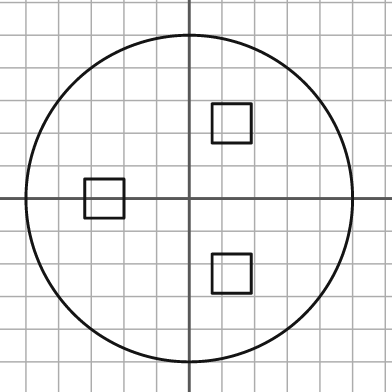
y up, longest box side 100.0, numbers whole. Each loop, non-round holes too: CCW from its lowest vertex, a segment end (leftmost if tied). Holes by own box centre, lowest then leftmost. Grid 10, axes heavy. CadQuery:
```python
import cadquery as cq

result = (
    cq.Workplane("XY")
    .moveTo(0.0, 0.0)
    .circle(50.0)
    .moveTo(7.0, -29.0)
    .lineTo(19.0, -29.0)
    .lineTo(19.0, -17.0)
    .lineTo(7.0, -17.0)
    .close()
    .moveTo(-32.0, -6.0)
    .lineTo(-20.0, -6.0)
    .lineTo(-20.0, 6.0)
    .lineTo(-32.0, 6.0)
    .close()
    .moveTo(7.0, 17.0)
    .lineTo(19.0, 17.0)
    .lineTo(19.0, 29.0)
    .lineTo(7.0, 29.0)
    .close()
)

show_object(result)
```